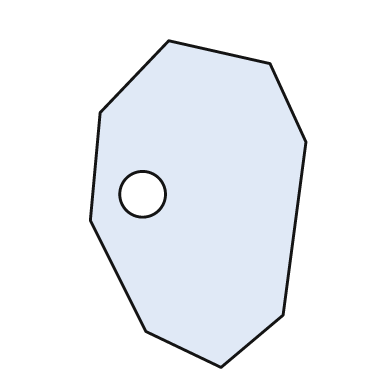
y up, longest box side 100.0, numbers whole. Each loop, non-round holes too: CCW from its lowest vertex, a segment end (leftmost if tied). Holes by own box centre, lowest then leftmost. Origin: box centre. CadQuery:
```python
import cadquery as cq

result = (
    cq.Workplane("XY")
    .moveTo(7.0, -50.0)
    .lineTo(26.0, -34.0)
    .lineTo(33.0, 19.0)
    .lineTo(22.0, 43.0)
    .lineTo(-9.0, 50.0)
    .lineTo(-30.0, 28.0)
    .lineTo(-33.0, -5.0)
    .lineTo(-16.0, -39.0)
    .close()
    .moveTo(-17.0, 3.0)
    .circle(7.0)
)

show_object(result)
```